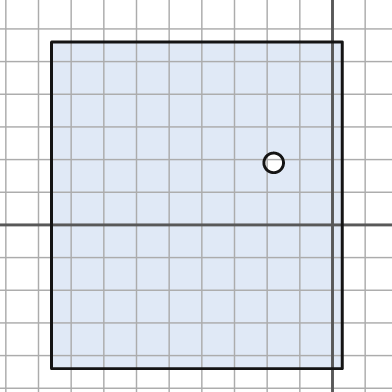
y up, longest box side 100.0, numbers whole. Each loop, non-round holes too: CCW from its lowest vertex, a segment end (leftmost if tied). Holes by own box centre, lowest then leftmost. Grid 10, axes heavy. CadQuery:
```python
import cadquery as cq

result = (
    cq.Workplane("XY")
    .moveTo(-86.0, -44.0)
    .lineTo(3.0, -44.0)
    .lineTo(3.0, 56.0)
    .lineTo(-86.0, 56.0)
    .close()
    .moveTo(-18.0, 19.0)
    .circle(3.0)
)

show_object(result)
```